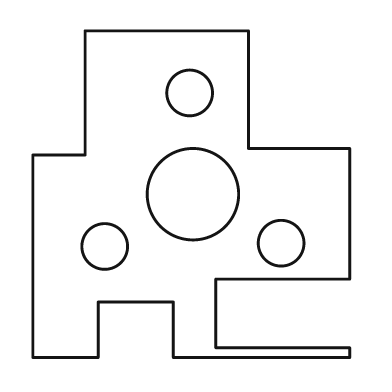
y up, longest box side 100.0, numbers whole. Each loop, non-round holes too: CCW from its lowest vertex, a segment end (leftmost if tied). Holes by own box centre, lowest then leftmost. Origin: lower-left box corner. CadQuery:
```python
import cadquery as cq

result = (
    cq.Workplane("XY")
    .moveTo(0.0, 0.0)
    .lineTo(20.0, 0.0)
    .lineTo(20.0, 17.0)
    .lineTo(43.0, 17.0)
    .lineTo(43.0, 0.0)
    .lineTo(97.0, 0.0)
    .lineTo(97.0, 3.0)
    .lineTo(56.0, 3.0)
    .lineTo(56.0, 24.0)
    .lineTo(97.0, 24.0)
    .lineTo(97.0, 64.0)
    .lineTo(66.0, 64.0)
    .lineTo(66.0, 100.0)
    .lineTo(16.0, 100.0)
    .lineTo(16.0, 62.0)
    .lineTo(0.0, 62.0)
    .close()
    .moveTo(22.0, 34.0)
    .circle(7.0)
    .moveTo(76.0, 35.0)
    .circle(7.0)
    .moveTo(49.0, 50.0)
    .circle(14.0)
    .moveTo(48.0, 81.0)
    .circle(7.0)
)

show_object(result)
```